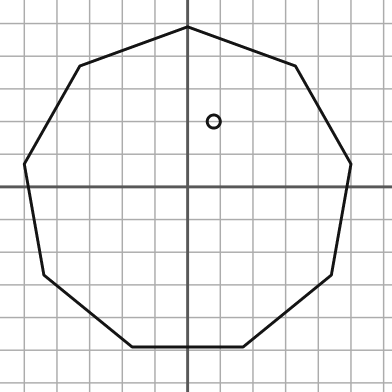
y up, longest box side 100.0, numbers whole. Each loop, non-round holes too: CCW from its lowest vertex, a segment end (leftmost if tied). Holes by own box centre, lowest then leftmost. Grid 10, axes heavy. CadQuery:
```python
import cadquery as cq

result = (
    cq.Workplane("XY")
    .moveTo(-17.0, -49.0)
    .lineTo(17.0, -49.0)
    .lineTo(44.0, -27.0)
    .lineTo(50.0, 7.0)
    .lineTo(33.0, 37.0)
    .lineTo(0.0, 49.0)
    .lineTo(-33.0, 37.0)
    .lineTo(-50.0, 7.0)
    .lineTo(-44.0, -27.0)
    .close()
    .moveTo(8.0, 20.0)
    .circle(2.0)
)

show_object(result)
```